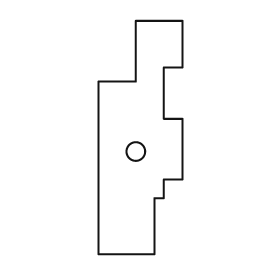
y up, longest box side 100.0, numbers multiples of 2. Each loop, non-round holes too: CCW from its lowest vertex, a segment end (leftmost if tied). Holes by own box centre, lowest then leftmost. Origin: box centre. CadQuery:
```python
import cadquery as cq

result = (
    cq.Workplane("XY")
    .moveTo(-18.0, -50.0)
    .lineTo(6.0, -50.0)
    .lineTo(6.0, -26.0)
    .lineTo(10.0, -26.0)
    .lineTo(10.0, -18.0)
    .lineTo(18.0, -18.0)
    .lineTo(18.0, 8.0)
    .lineTo(10.0, 8.0)
    .lineTo(10.0, 30.0)
    .lineTo(18.0, 30.0)
    .lineTo(18.0, 50.0)
    .lineTo(-2.0, 50.0)
    .lineTo(-2.0, 24.0)
    .lineTo(-18.0, 24.0)
    .close()
    .moveTo(-2.0, -6.0)
    .circle(4.0)
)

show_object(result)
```